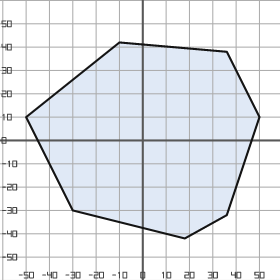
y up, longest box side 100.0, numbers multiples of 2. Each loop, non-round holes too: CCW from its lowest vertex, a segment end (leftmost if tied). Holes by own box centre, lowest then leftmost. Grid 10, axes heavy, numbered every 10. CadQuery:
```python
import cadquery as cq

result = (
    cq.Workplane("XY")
    .moveTo(18.0, -42.0)
    .lineTo(36.0, -32.0)
    .lineTo(50.0, 10.0)
    .lineTo(36.0, 38.0)
    .lineTo(-10.0, 42.0)
    .lineTo(-50.0, 10.0)
    .lineTo(-30.0, -30.0)
    .close()
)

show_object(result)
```